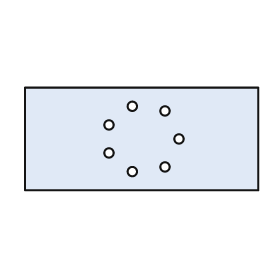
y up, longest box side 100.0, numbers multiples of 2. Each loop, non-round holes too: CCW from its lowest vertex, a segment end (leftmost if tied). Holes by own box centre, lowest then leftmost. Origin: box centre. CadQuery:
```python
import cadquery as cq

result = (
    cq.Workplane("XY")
    .moveTo(-50.0, -22.0)
    .lineTo(50.0, -22.0)
    .lineTo(50.0, 22.0)
    .lineTo(-50.0, 22.0)
    .close()
    .moveTo(-4.0, -14.0)
    .circle(2.0)
    .moveTo(10.0, -12.0)
    .circle(2.0)
    .moveTo(-14.0, -6.0)
    .circle(2.0)
    .moveTo(16.0, 0.0)
    .circle(2.0)
    .moveTo(-14.0, 6.0)
    .circle(2.0)
    .moveTo(10.0, 12.0)
    .circle(2.0)
    .moveTo(-4.0, 14.0)
    .circle(2.0)
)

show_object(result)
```